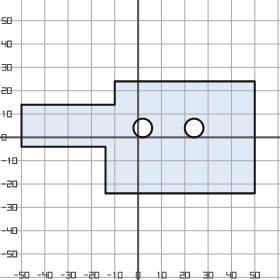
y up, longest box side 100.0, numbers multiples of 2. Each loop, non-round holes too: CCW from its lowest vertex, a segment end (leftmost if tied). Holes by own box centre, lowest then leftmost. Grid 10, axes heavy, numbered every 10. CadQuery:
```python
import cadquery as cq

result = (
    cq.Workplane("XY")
    .moveTo(-14.0, -24.0)
    .lineTo(50.0, -24.0)
    .lineTo(50.0, 24.0)
    .lineTo(-10.0, 24.0)
    .lineTo(-10.0, 14.0)
    .lineTo(-50.0, 14.0)
    .lineTo(-50.0, -4.0)
    .lineTo(-14.0, -4.0)
    .close()
    .moveTo(2.0, 4.0)
    .circle(4.0)
    .moveTo(24.0, 4.0)
    .circle(4.0)
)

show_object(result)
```